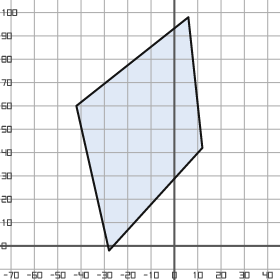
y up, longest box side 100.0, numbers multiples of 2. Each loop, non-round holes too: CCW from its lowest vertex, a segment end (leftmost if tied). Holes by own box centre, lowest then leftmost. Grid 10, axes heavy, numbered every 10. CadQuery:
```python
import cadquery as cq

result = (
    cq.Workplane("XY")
    .moveTo(-28.0, -2.0)
    .lineTo(12.0, 42.0)
    .lineTo(6.0, 98.0)
    .lineTo(-42.0, 60.0)
    .close()
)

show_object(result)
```